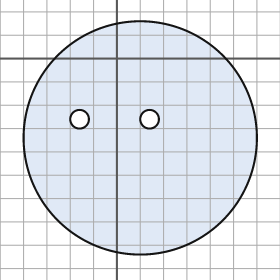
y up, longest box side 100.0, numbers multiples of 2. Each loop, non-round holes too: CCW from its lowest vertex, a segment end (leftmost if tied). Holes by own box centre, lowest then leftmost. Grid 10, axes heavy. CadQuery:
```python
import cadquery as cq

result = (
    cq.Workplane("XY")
    .moveTo(10.0, -34.0)
    .circle(50.0)
    .moveTo(-16.0, -26.0)
    .circle(4.0)
    .moveTo(14.0, -26.0)
    .circle(4.0)
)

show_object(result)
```